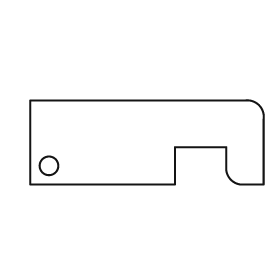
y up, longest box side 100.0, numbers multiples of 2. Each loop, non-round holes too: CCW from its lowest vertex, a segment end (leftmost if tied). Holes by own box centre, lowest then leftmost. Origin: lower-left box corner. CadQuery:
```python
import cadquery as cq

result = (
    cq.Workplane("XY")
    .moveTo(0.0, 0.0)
    .lineTo(62.0, 0.0)
    .lineTo(62.0, 16.0)
    .lineTo(84.0, 16.0)
    .lineTo(84.0, 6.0)
    .threePointArc((86.0, 2.0), (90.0, 0.0))
    .lineTo(100.0, 0.0)
    .lineTo(100.0, 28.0)
    .threePointArc((98.0, 34.0), (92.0, 36.0))
    .lineTo(0.0, 36.0)
    .close()
    .moveTo(8.0, 8.0)
    .circle(4.0)
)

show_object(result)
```